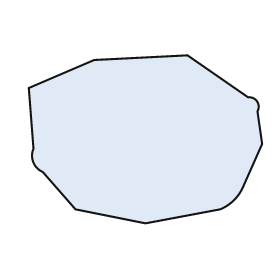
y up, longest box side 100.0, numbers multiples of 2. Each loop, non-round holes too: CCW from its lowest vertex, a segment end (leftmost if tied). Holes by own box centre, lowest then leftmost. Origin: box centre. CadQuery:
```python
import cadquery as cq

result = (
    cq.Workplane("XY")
    .moveTo(0.0, -36.0)
    .lineTo(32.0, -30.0)
    .threePointArc((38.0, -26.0), (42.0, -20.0))
    .lineTo(50.0, -2.0)
    .lineTo(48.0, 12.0)
    .threePointArc((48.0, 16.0), (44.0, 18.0))
    .lineTo(18.0, 36.0)
    .lineTo(-22.0, 34.0)
    .lineTo(-50.0, 22.0)
    .lineTo(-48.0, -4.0)
    .threePointArc((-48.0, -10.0), (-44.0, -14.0))
    .lineTo(-30.0, -30.0)
    .close()
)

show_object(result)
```